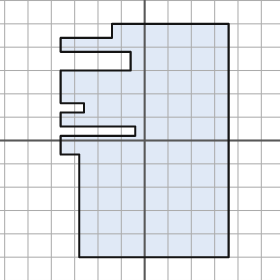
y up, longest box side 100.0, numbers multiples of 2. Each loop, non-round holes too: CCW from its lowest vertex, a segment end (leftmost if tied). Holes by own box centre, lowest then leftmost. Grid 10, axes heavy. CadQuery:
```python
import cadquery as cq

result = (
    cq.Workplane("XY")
    .moveTo(-28.0, -50.0)
    .lineTo(36.0, -50.0)
    .lineTo(36.0, 50.0)
    .lineTo(-14.0, 50.0)
    .lineTo(-14.0, 44.0)
    .lineTo(-36.0, 44.0)
    .lineTo(-36.0, 38.0)
    .lineTo(-6.0, 38.0)
    .lineTo(-6.0, 30.0)
    .lineTo(-36.0, 30.0)
    .lineTo(-36.0, 16.0)
    .lineTo(-26.0, 16.0)
    .lineTo(-26.0, 12.0)
    .lineTo(-36.0, 12.0)
    .lineTo(-36.0, 6.0)
    .lineTo(-4.0, 6.0)
    .lineTo(-4.0, 2.0)
    .lineTo(-36.0, 2.0)
    .lineTo(-36.0, -6.0)
    .lineTo(-28.0, -6.0)
    .close()
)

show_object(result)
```